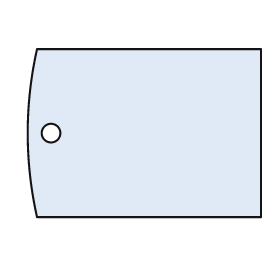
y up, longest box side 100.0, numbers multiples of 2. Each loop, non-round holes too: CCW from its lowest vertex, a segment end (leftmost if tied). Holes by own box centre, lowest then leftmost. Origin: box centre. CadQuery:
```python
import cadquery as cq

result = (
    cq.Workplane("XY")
    .moveTo(-46.0, -36.0)
    .lineTo(50.0, -36.0)
    .lineTo(50.0, 36.0)
    .lineTo(-46.0, 36.0)
    .threePointArc((-50.0, 0.0), (-46.0, -36.0))
    .close()
    .moveTo(-40.0, 0.0)
    .circle(4.0)
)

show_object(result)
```